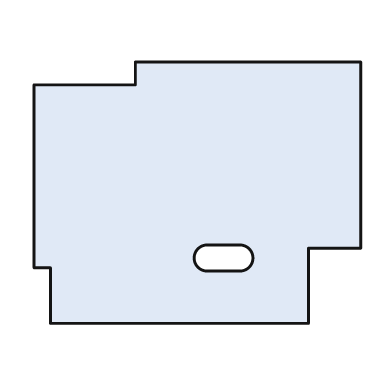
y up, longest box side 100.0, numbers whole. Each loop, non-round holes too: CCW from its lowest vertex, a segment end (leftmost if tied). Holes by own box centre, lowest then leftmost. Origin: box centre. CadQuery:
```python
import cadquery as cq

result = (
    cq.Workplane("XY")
    .moveTo(-45.0, -40.0)
    .lineTo(34.0, -40.0)
    .lineTo(34.0, -17.0)
    .lineTo(50.0, -17.0)
    .lineTo(50.0, 40.0)
    .lineTo(-19.0, 40.0)
    .lineTo(-19.0, 33.0)
    .lineTo(-50.0, 33.0)
    .lineTo(-50.0, -23.0)
    .lineTo(-45.0, -23.0)
    .close()
    .moveTo(3.0, -24.0)
    .lineTo(13.0, -24.0)
    .threePointArc((17.0, -20.0), (13.0, -16.0))
    .lineTo(3.0, -16.0)
    .threePointArc((-1.0, -20.0), (3.0, -24.0))
    .close()
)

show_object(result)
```